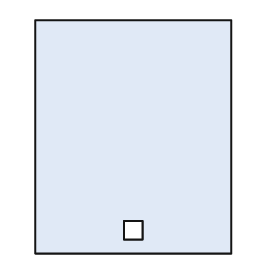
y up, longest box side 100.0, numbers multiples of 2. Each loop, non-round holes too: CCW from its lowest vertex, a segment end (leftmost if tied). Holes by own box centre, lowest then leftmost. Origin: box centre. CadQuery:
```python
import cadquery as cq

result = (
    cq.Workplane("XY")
    .moveTo(-42.0, -50.0)
    .lineTo(42.0, -50.0)
    .lineTo(42.0, 50.0)
    .lineTo(-42.0, 50.0)
    .close()
    .moveTo(-4.0, -44.0)
    .lineTo(4.0, -44.0)
    .lineTo(4.0, -36.0)
    .lineTo(-4.0, -36.0)
    .close()
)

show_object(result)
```